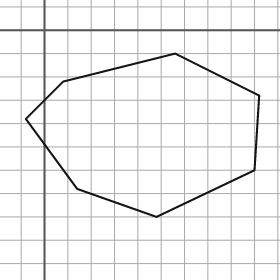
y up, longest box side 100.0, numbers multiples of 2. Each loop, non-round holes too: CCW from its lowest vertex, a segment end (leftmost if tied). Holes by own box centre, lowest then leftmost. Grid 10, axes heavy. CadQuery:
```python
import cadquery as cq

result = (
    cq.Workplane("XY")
    .moveTo(48.0, -80.0)
    .lineTo(90.0, -60.0)
    .lineTo(92.0, -28.0)
    .lineTo(56.0, -10.0)
    .lineTo(8.0, -22.0)
    .lineTo(-8.0, -38.0)
    .lineTo(14.0, -68.0)
    .close()
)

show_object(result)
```